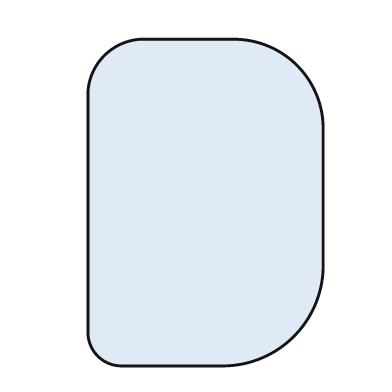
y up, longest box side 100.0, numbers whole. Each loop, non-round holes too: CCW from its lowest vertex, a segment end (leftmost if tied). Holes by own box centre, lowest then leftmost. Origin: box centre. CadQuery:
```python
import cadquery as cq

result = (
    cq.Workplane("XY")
    .moveTo(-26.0, -50.0)
    .lineTo(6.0, -50.0)
    .threePointArc((27.0, -41.0), (36.0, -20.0))
    .lineTo(36.0, 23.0)
    .threePointArc((28.0, 42.0), (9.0, 50.0))
    .lineTo(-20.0, 50.0)
    .threePointArc((-31.0, 45.0), (-36.0, 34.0))
    .lineTo(-36.0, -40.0)
    .threePointArc((-33.0, -47.0), (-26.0, -50.0))
    .close()
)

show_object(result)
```